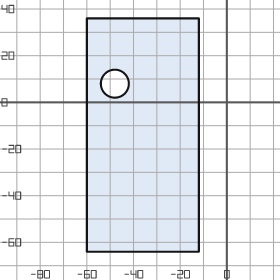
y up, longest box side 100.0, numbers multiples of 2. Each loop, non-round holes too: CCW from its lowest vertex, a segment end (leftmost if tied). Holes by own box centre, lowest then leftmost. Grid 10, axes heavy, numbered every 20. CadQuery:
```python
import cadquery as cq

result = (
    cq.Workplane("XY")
    .moveTo(-60.0, -64.0)
    .lineTo(-12.0, -64.0)
    .lineTo(-12.0, 36.0)
    .lineTo(-60.0, 36.0)
    .close()
    .moveTo(-48.0, 8.0)
    .circle(6.0)
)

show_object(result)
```